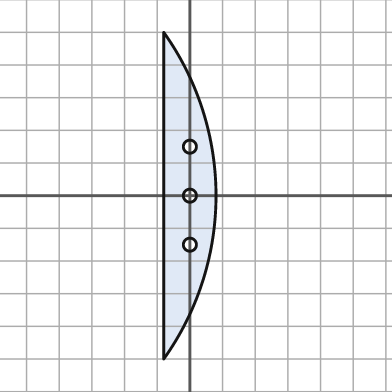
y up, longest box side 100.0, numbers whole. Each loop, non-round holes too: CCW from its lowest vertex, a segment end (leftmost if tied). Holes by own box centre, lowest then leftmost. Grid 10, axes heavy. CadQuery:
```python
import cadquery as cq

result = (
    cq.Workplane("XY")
    .moveTo(-8.0, -50.0)
    .threePointArc((8.0, 0.0), (-8.0, 50.0))
    .close()
    .moveTo(0.0, -15.0)
    .circle(2.0)
    .moveTo(0.0, 0.0)
    .circle(2.0)
    .moveTo(0.0, 15.0)
    .circle(2.0)
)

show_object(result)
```